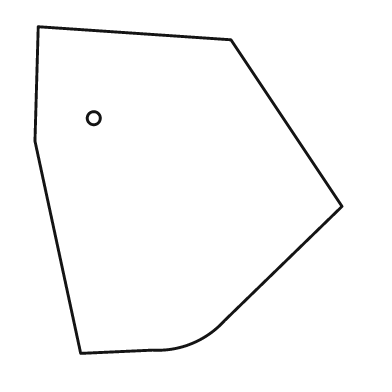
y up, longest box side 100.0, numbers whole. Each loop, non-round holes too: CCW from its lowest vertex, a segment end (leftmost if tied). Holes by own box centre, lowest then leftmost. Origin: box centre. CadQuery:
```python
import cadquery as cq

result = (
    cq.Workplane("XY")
    .moveTo(-33.0, -50.0)
    .lineTo(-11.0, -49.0)
    .threePointArc((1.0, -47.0), (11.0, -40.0))
    .lineTo(47.0, -5.0)
    .lineTo(13.0, 46.0)
    .lineTo(-46.0, 50.0)
    .lineTo(-47.0, 15.0)
    .close()
    .moveTo(-29.0, 22.0)
    .circle(2.0)
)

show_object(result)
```